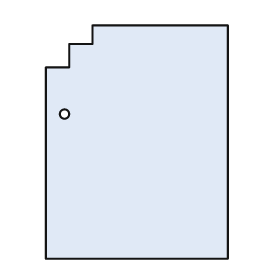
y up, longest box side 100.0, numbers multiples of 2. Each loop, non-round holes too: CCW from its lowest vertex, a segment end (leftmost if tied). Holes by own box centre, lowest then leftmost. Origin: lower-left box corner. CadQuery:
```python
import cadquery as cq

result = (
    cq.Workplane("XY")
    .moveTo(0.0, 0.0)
    .lineTo(78.0, 0.0)
    .lineTo(78.0, 100.0)
    .lineTo(20.0, 100.0)
    .lineTo(20.0, 92.0)
    .lineTo(10.0, 92.0)
    .lineTo(10.0, 82.0)
    .lineTo(0.0, 82.0)
    .close()
    .moveTo(8.0, 62.0)
    .circle(2.0)
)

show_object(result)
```